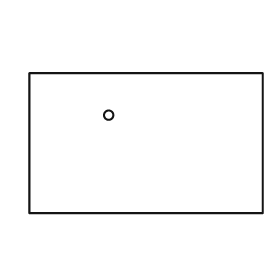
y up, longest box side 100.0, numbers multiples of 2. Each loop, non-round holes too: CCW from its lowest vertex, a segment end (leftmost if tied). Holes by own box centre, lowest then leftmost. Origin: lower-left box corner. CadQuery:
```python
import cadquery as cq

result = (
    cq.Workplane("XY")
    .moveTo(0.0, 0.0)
    .lineTo(100.0, 0.0)
    .lineTo(100.0, 60.0)
    .lineTo(0.0, 60.0)
    .close()
    .moveTo(34.0, 42.0)
    .circle(2.0)
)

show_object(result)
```